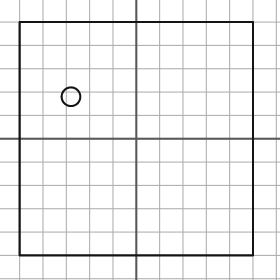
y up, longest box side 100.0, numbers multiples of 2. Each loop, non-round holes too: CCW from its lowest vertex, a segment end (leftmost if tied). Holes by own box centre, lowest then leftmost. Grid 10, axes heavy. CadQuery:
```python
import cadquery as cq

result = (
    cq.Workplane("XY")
    .moveTo(-50.0, -50.0)
    .lineTo(50.0, -50.0)
    .lineTo(50.0, 50.0)
    .lineTo(-50.0, 50.0)
    .close()
    .moveTo(-28.0, 18.0)
    .circle(4.0)
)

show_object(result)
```